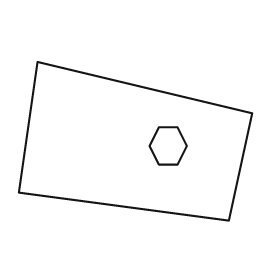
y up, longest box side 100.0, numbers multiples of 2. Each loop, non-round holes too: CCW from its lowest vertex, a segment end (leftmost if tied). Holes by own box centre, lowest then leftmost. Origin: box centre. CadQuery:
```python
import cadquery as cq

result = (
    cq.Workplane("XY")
    .moveTo(40.0, -34.0)
    .lineTo(50.0, 12.0)
    .lineTo(-42.0, 34.0)
    .lineTo(-50.0, -22.0)
    .close()
    .moveTo(10.0, -10.0)
    .lineTo(18.0, -10.0)
    .lineTo(22.0, -2.0)
    .lineTo(18.0, 6.0)
    .lineTo(10.0, 6.0)
    .lineTo(6.0, -2.0)
    .close()
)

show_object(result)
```